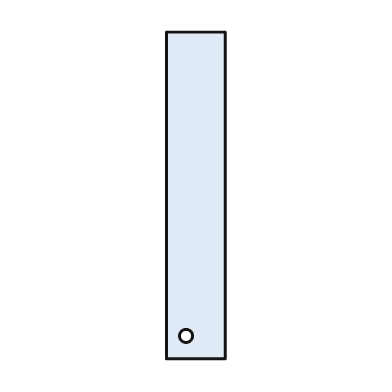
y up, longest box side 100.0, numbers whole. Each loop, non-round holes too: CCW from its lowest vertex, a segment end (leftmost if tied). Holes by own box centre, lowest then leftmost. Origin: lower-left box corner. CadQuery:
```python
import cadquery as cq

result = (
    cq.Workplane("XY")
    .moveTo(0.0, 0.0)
    .lineTo(18.0, 0.0)
    .lineTo(18.0, 100.0)
    .lineTo(0.0, 100.0)
    .close()
    .moveTo(6.0, 7.0)
    .circle(2.0)
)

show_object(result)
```